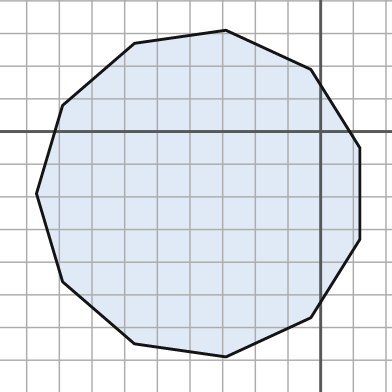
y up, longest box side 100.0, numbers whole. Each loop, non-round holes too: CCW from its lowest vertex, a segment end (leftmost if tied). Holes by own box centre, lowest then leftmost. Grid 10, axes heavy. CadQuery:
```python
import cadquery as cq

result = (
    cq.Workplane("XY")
    .moveTo(-29.0, -69.0)
    .lineTo(-3.0, -57.0)
    .lineTo(12.0, -33.0)
    .lineTo(12.0, -5.0)
    .lineTo(-3.0, 19.0)
    .lineTo(-29.0, 31.0)
    .lineTo(-57.0, 27.0)
    .lineTo(-79.0, 8.0)
    .lineTo(-87.0, -19.0)
    .lineTo(-79.0, -46.0)
    .lineTo(-57.0, -65.0)
    .close()
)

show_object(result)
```